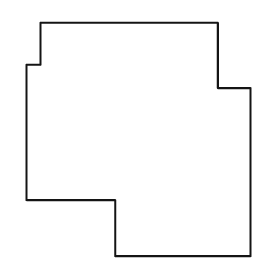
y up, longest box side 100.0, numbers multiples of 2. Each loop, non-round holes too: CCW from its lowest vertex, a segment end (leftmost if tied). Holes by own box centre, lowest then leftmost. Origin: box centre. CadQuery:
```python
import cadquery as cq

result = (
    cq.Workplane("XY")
    .moveTo(-10.0, -50.0)
    .lineTo(48.0, -50.0)
    .lineTo(48.0, 22.0)
    .lineTo(34.0, 22.0)
    .lineTo(34.0, 50.0)
    .lineTo(-42.0, 50.0)
    .lineTo(-42.0, 32.0)
    .lineTo(-48.0, 32.0)
    .lineTo(-48.0, -26.0)
    .lineTo(-10.0, -26.0)
    .close()
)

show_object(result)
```